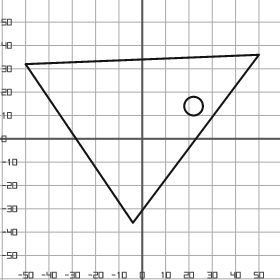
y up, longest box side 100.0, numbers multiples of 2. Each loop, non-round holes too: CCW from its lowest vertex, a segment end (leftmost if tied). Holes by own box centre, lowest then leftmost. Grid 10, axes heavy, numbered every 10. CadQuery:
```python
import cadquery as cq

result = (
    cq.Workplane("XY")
    .moveTo(-4.0, -36.0)
    .lineTo(50.0, 36.0)
    .lineTo(-50.0, 32.0)
    .close()
    .moveTo(22.0, 14.0)
    .circle(4.0)
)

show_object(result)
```